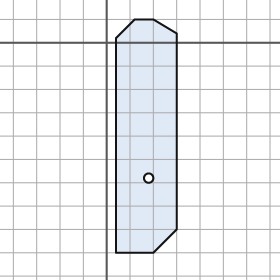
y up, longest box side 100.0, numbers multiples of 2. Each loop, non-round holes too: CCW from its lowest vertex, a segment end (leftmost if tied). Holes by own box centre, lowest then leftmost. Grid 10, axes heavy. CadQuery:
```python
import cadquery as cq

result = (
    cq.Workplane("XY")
    .moveTo(4.0, -90.0)
    .lineTo(20.0, -90.0)
    .lineTo(30.0, -80.0)
    .lineTo(30.0, 4.0)
    .lineTo(20.0, 10.0)
    .lineTo(12.0, 10.0)
    .lineTo(4.0, 2.0)
    .close()
    .moveTo(18.0, -58.0)
    .circle(2.0)
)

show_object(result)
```